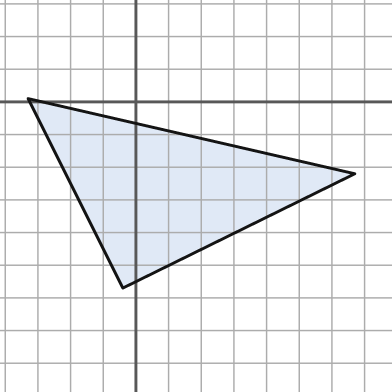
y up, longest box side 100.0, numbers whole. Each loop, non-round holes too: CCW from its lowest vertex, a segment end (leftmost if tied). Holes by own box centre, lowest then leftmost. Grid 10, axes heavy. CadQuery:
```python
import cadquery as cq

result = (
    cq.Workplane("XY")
    .moveTo(-4.0, -57.0)
    .lineTo(67.0, -22.0)
    .lineTo(-33.0, 1.0)
    .close()
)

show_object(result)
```